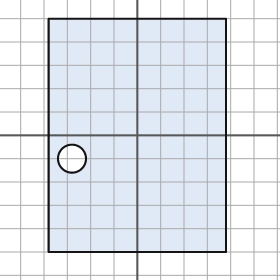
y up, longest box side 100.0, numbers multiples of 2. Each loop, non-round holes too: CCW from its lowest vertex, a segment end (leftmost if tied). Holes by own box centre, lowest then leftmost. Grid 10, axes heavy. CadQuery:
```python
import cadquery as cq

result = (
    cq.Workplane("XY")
    .moveTo(-38.0, -50.0)
    .lineTo(38.0, -50.0)
    .lineTo(38.0, 50.0)
    .lineTo(-38.0, 50.0)
    .close()
    .moveTo(-28.0, -10.0)
    .circle(6.0)
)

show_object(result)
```